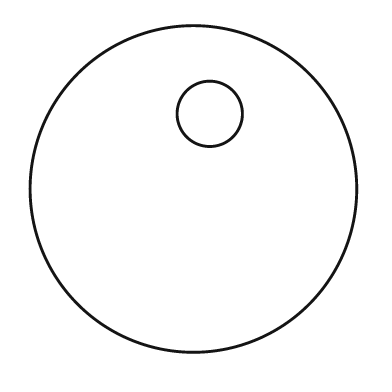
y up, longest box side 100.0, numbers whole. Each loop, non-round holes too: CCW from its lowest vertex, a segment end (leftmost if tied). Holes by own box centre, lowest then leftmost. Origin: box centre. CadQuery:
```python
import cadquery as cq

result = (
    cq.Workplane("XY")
    .moveTo(0.0, 0.0)
    .circle(50.0)
    .moveTo(5.0, 23.0)
    .circle(10.0)
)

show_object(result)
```